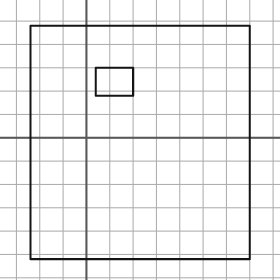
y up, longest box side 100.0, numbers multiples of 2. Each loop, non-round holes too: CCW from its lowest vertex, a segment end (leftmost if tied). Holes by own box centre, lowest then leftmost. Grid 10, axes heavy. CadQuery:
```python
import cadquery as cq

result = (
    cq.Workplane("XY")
    .moveTo(-24.0, -52.0)
    .lineTo(70.0, -52.0)
    .lineTo(70.0, 48.0)
    .lineTo(-24.0, 48.0)
    .close()
    .moveTo(4.0, 18.0)
    .lineTo(20.0, 18.0)
    .lineTo(20.0, 30.0)
    .lineTo(4.0, 30.0)
    .close()
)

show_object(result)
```